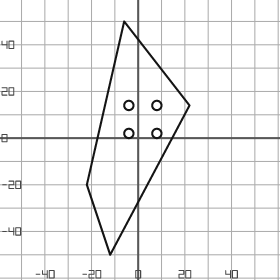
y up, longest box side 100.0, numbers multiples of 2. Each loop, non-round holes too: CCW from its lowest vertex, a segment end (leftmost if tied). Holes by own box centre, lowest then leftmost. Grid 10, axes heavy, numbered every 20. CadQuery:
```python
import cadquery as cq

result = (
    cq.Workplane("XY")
    .moveTo(-12.0, -50.0)
    .lineTo(22.0, 14.0)
    .lineTo(-6.0, 50.0)
    .lineTo(-22.0, -20.0)
    .close()
    .moveTo(-4.0, 2.0)
    .circle(2.0)
    .moveTo(8.0, 2.0)
    .circle(2.0)
    .moveTo(-4.0, 14.0)
    .circle(2.0)
    .moveTo(8.0, 14.0)
    .circle(2.0)
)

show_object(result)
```